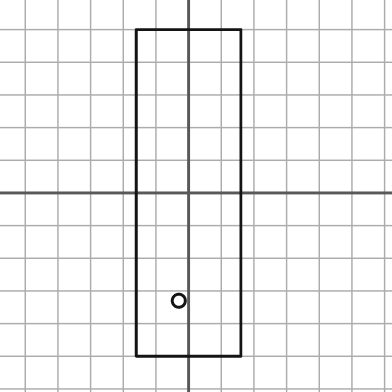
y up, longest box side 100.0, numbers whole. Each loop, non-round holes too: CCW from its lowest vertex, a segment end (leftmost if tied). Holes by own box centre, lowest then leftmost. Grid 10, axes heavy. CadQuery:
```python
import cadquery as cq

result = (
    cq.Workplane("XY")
    .moveTo(-16.0, -50.0)
    .lineTo(16.0, -50.0)
    .lineTo(16.0, 50.0)
    .lineTo(-16.0, 50.0)
    .close()
    .moveTo(-3.0, -33.0)
    .circle(2.0)
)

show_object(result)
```